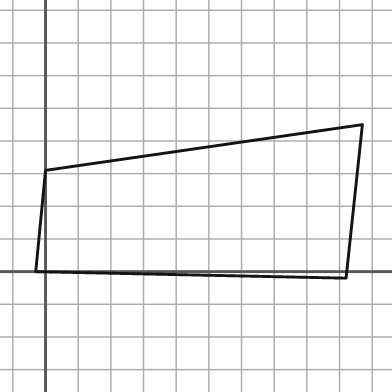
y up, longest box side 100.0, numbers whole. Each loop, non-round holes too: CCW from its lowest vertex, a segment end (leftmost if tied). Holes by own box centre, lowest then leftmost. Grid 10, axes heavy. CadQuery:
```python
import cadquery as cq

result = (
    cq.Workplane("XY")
    .moveTo(92.0, -2.0)
    .lineTo(97.0, 45.0)
    .lineTo(0.0, 31.0)
    .lineTo(-3.0, 0.0)
    .close()
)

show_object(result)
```